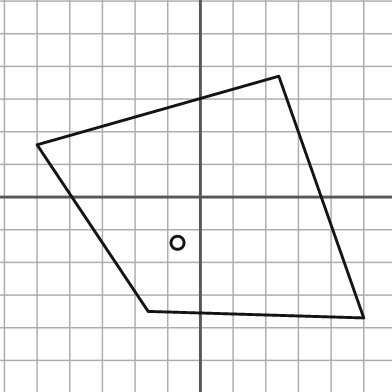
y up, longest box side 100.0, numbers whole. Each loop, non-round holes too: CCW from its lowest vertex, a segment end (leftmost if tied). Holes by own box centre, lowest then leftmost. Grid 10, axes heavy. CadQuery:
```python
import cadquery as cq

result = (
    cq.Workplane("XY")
    .moveTo(50.0, -37.0)
    .lineTo(24.0, 37.0)
    .lineTo(-50.0, 16.0)
    .lineTo(-16.0, -35.0)
    .close()
    .moveTo(-7.0, -14.0)
    .circle(2.0)
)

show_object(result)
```